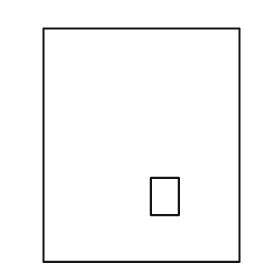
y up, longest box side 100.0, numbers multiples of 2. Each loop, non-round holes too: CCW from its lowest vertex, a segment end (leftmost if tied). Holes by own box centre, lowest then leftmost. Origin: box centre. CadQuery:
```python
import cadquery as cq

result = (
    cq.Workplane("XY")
    .moveTo(-42.0, -50.0)
    .lineTo(42.0, -50.0)
    .lineTo(42.0, 50.0)
    .lineTo(-42.0, 50.0)
    .close()
    .moveTo(4.0, -30.0)
    .lineTo(16.0, -30.0)
    .lineTo(16.0, -14.0)
    .lineTo(4.0, -14.0)
    .close()
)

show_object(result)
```